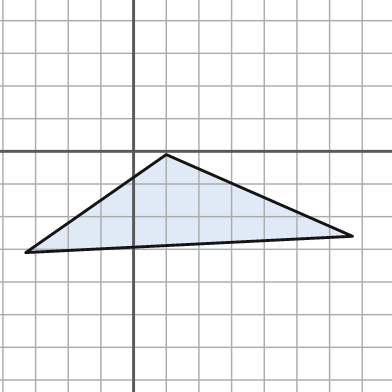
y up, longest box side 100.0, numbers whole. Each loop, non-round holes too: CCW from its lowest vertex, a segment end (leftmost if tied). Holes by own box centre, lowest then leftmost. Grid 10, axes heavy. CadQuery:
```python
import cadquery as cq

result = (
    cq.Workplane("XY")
    .moveTo(-33.0, -31.0)
    .lineTo(67.0, -26.0)
    .lineTo(10.0, -1.0)
    .close()
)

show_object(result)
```